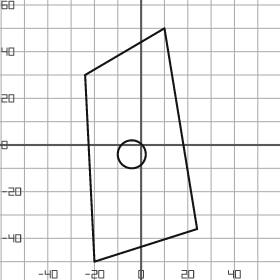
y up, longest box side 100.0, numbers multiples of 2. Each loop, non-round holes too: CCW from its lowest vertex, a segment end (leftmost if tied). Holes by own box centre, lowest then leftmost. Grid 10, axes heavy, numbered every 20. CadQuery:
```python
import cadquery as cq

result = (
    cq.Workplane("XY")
    .moveTo(-20.0, -50.0)
    .lineTo(24.0, -36.0)
    .lineTo(10.0, 50.0)
    .lineTo(-24.0, 30.0)
    .close()
    .moveTo(-4.0, -4.0)
    .circle(6.0)
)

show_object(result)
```